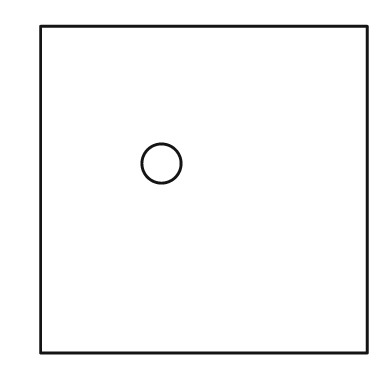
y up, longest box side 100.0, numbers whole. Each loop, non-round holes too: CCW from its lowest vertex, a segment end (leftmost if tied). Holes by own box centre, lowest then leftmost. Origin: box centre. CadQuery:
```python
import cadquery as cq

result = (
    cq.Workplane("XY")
    .moveTo(-50.0, -50.0)
    .lineTo(50.0, -50.0)
    .lineTo(50.0, 50.0)
    .lineTo(-50.0, 50.0)
    .close()
    .moveTo(-13.0, 8.0)
    .circle(6.0)
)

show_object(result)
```